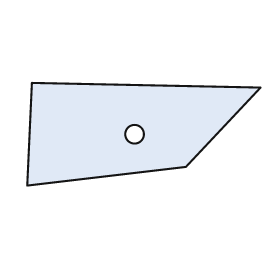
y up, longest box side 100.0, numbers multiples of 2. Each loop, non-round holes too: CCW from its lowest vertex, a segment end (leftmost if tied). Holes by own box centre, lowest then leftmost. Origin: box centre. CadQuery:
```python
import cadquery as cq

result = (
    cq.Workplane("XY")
    .moveTo(-50.0, -22.0)
    .lineTo(18.0, -14.0)
    .lineTo(50.0, 20.0)
    .lineTo(-48.0, 22.0)
    .close()
    .moveTo(-4.0, 0.0)
    .circle(4.0)
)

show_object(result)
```